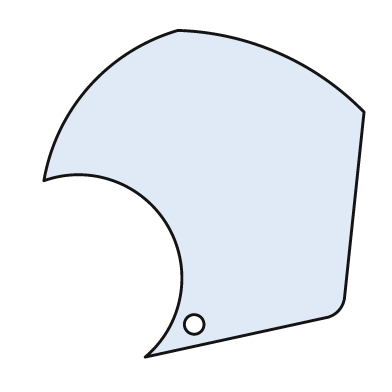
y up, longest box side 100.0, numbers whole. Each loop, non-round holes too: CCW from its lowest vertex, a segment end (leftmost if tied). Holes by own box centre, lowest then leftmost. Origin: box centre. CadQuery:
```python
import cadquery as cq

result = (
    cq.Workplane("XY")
    .moveTo(-18.0, -50.0)
    .lineTo(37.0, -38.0)
    .threePointArc((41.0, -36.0), (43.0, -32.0))
    .lineTo(49.0, 25.0)
    .threePointArc((23.0, 43.0), (-8.0, 50.0))
    .threePointArc((-35.0, 33.0), (-49.0, 4.0))
    .threePointArc((-11.0, -10.0), (-18.0, -50.0))
    .close()
    .moveTo(-3.0, -40.0)
    .circle(3.0)
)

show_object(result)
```